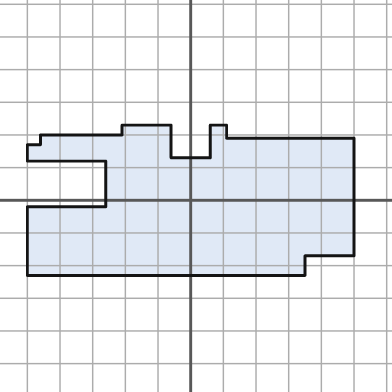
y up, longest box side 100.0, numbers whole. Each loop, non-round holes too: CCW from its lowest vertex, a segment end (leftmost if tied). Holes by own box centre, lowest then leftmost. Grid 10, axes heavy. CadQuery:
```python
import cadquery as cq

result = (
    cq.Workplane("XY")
    .moveTo(-50.0, -23.0)
    .lineTo(35.0, -23.0)
    .lineTo(35.0, -17.0)
    .lineTo(50.0, -17.0)
    .lineTo(50.0, 19.0)
    .lineTo(11.0, 19.0)
    .lineTo(11.0, 23.0)
    .lineTo(6.0, 23.0)
    .lineTo(6.0, 13.0)
    .lineTo(-6.0, 13.0)
    .lineTo(-6.0, 23.0)
    .lineTo(-21.0, 23.0)
    .lineTo(-21.0, 20.0)
    .lineTo(-46.0, 20.0)
    .lineTo(-46.0, 17.0)
    .lineTo(-50.0, 17.0)
    .lineTo(-50.0, 12.0)
    .lineTo(-26.0, 12.0)
    .lineTo(-26.0, -2.0)
    .lineTo(-50.0, -2.0)
    .close()
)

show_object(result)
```